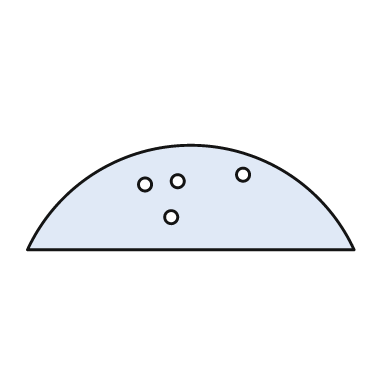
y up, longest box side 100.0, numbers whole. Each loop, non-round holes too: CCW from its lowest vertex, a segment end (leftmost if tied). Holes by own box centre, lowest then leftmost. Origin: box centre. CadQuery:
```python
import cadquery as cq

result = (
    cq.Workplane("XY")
    .moveTo(-50.0, -16.0)
    .lineTo(50.0, -16.0)
    .threePointArc((0.0, 16.0), (-50.0, -16.0))
    .close()
    .moveTo(-6.0, -6.0)
    .circle(2.0)
    .moveTo(-14.0, 4.0)
    .circle(2.0)
    .moveTo(-4.0, 5.0)
    .circle(2.0)
    .moveTo(16.0, 7.0)
    .circle(2.0)
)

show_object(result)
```